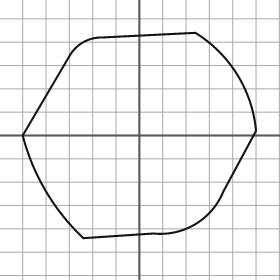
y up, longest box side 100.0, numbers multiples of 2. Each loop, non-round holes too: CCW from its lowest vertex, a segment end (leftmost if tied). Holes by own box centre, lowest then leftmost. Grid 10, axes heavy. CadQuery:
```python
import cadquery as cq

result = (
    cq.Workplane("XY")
    .moveTo(-24.0, -44.0)
    .lineTo(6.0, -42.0)
    .threePointArc((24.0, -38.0), (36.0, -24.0))
    .lineTo(50.0, 2.0)
    .threePointArc((42.0, 26.0), (24.0, 44.0))
    .lineTo(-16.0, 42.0)
    .threePointArc((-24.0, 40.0), (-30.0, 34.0))
    .lineTo(-50.0, 0.0)
    .threePointArc((-40.0, -24.0), (-24.0, -44.0))
    .close()
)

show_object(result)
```